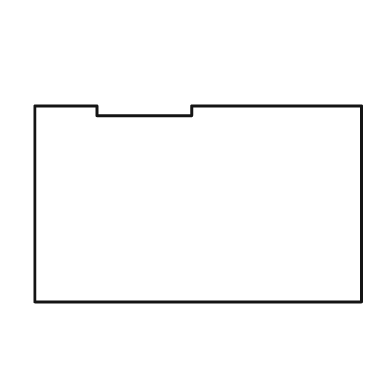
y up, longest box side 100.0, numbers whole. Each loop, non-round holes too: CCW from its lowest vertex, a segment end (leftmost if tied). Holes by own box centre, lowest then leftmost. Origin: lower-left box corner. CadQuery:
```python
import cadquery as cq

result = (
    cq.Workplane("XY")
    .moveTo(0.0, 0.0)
    .lineTo(100.0, 0.0)
    .lineTo(100.0, 60.0)
    .lineTo(48.0, 60.0)
    .lineTo(48.0, 57.0)
    .lineTo(19.0, 57.0)
    .lineTo(19.0, 60.0)
    .lineTo(0.0, 60.0)
    .close()
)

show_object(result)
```